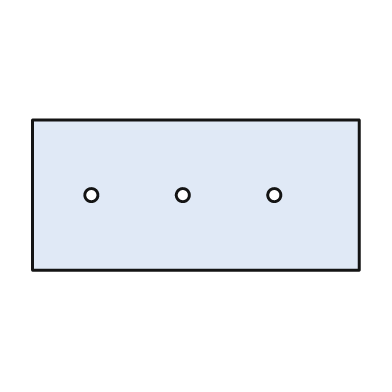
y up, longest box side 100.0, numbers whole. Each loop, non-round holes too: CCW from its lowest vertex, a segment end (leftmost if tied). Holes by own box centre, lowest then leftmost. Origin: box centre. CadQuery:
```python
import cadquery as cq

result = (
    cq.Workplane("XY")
    .moveTo(-50.0, -23.0)
    .lineTo(50.0, -23.0)
    .lineTo(50.0, 23.0)
    .lineTo(-50.0, 23.0)
    .close()
    .moveTo(-32.0, 0.0)
    .circle(2.0)
    .moveTo(-4.0, 0.0)
    .circle(2.0)
    .moveTo(24.0, 0.0)
    .circle(2.0)
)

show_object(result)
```